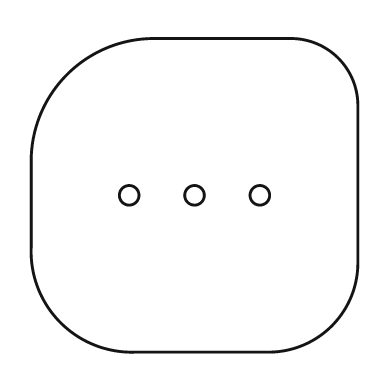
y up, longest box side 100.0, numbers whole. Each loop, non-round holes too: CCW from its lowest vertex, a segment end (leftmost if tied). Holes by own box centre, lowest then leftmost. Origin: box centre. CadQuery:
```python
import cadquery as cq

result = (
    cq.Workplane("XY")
    .moveTo(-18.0, -48.0)
    .lineTo(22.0, -48.0)
    .threePointArc((42.0, -40.0), (50.0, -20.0))
    .lineTo(50.0, 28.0)
    .threePointArc((44.0, 42.0), (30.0, 48.0))
    .lineTo(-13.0, 48.0)
    .threePointArc((-39.0, 37.0), (-50.0, 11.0))
    .lineTo(-50.0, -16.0)
    .threePointArc((-41.0, -39.0), (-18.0, -48.0))
    .close()
    .moveTo(-20.0, 0.0)
    .circle(3.0)
    .moveTo(0.0, 0.0)
    .circle(3.0)
    .moveTo(20.0, 0.0)
    .circle(3.0)
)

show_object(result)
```